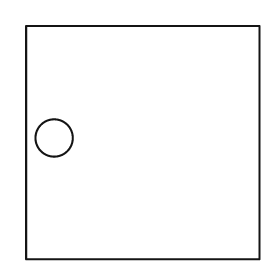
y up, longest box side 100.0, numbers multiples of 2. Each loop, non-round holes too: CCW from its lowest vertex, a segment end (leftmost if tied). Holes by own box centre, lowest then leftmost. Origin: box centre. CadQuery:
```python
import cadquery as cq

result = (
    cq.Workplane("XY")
    .moveTo(-50.0, -50.0)
    .lineTo(50.0, -50.0)
    .lineTo(50.0, 50.0)
    .lineTo(-50.0, 50.0)
    .close()
    .moveTo(-38.0, 2.0)
    .circle(8.0)
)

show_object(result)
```